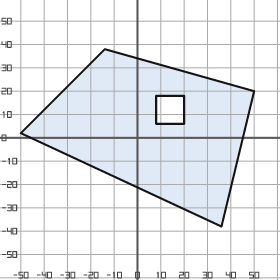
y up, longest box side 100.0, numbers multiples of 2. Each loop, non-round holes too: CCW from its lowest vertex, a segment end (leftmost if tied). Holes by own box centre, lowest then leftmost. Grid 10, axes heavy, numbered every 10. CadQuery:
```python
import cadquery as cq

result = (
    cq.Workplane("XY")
    .moveTo(36.0, -38.0)
    .lineTo(50.0, 20.0)
    .lineTo(-14.0, 38.0)
    .lineTo(-50.0, 2.0)
    .close()
    .moveTo(8.0, 6.0)
    .lineTo(20.0, 6.0)
    .lineTo(20.0, 18.0)
    .lineTo(8.0, 18.0)
    .close()
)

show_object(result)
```